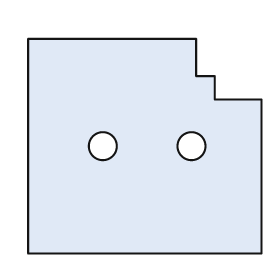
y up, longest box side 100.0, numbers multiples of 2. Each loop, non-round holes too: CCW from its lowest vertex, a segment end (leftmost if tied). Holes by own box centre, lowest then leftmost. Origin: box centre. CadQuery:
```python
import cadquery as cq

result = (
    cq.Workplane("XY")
    .moveTo(-50.0, -46.0)
    .lineTo(50.0, -46.0)
    .lineTo(50.0, 20.0)
    .lineTo(30.0, 20.0)
    .lineTo(30.0, 30.0)
    .lineTo(22.0, 30.0)
    .lineTo(22.0, 46.0)
    .lineTo(-50.0, 46.0)
    .close()
    .moveTo(-18.0, 0.0)
    .circle(6.0)
    .moveTo(20.0, 0.0)
    .circle(6.0)
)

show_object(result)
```